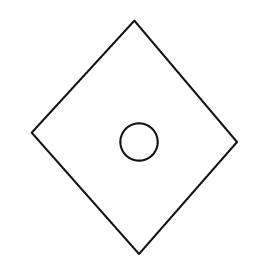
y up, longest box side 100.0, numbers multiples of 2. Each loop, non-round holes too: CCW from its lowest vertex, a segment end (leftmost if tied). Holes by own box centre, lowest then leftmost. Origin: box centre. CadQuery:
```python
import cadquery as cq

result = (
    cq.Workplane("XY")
    .moveTo(2.0, -50.0)
    .lineTo(44.0, -2.0)
    .lineTo(0.0, 50.0)
    .lineTo(-44.0, 2.0)
    .close()
    .moveTo(2.0, -2.0)
    .circle(8.0)
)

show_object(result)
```